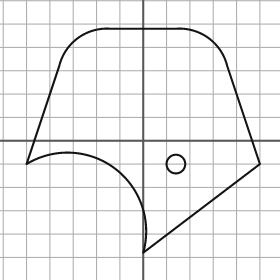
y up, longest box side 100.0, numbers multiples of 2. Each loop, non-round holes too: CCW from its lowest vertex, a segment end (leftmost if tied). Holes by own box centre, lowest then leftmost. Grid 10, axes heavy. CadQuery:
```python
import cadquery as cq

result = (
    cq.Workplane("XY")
    .moveTo(0.0, -48.0)
    .lineTo(50.0, -10.0)
    .lineTo(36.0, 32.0)
    .threePointArc((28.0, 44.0), (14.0, 48.0))
    .lineTo(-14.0, 48.0)
    .threePointArc((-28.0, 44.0), (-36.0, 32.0))
    .lineTo(-50.0, -10.0)
    .threePointArc((-12.0, -12.0), (0.0, -48.0))
    .close()
    .moveTo(14.0, -10.0)
    .circle(4.0)
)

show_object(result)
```